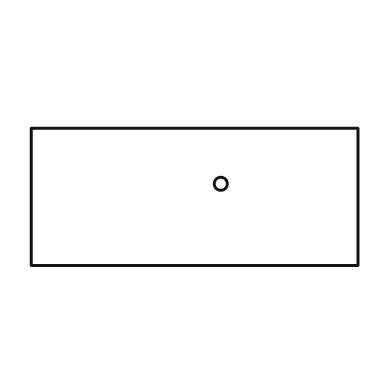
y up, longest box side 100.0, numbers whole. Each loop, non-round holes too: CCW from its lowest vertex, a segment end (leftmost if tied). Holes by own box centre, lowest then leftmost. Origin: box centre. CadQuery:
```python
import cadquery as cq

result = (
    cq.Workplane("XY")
    .moveTo(-50.0, -21.0)
    .lineTo(50.0, -21.0)
    .lineTo(50.0, 21.0)
    .lineTo(-50.0, 21.0)
    .close()
    .moveTo(8.0, 4.0)
    .circle(2.0)
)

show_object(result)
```